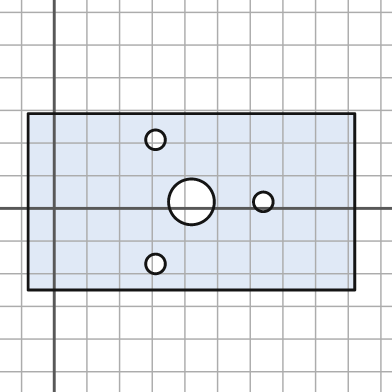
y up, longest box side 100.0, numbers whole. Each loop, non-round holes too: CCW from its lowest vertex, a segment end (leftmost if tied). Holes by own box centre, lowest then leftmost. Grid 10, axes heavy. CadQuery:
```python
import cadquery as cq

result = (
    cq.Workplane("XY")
    .moveTo(-8.0, -25.0)
    .lineTo(92.0, -25.0)
    .lineTo(92.0, 29.0)
    .lineTo(-8.0, 29.0)
    .close()
    .moveTo(31.0, -17.0)
    .circle(3.0)
    .moveTo(42.0, 2.0)
    .circle(7.0)
    .moveTo(64.0, 2.0)
    .circle(3.0)
    .moveTo(31.0, 21.0)
    .circle(3.0)
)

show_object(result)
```